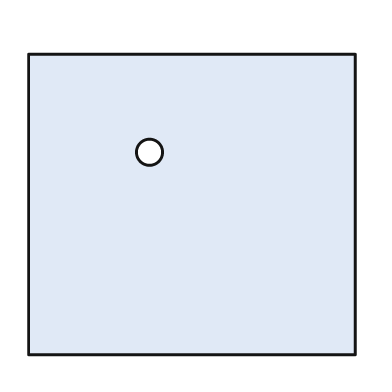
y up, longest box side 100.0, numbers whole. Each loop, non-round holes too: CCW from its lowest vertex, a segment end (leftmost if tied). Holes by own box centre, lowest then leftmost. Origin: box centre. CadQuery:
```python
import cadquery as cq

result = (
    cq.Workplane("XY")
    .moveTo(-50.0, -46.0)
    .lineTo(50.0, -46.0)
    .lineTo(50.0, 46.0)
    .lineTo(-50.0, 46.0)
    .close()
    .moveTo(-13.0, 16.0)
    .circle(4.0)
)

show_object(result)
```